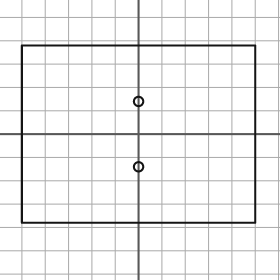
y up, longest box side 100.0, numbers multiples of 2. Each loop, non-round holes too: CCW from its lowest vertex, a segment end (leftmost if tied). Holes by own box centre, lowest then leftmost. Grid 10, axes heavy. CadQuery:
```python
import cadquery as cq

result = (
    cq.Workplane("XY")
    .moveTo(-50.0, -38.0)
    .lineTo(50.0, -38.0)
    .lineTo(50.0, 38.0)
    .lineTo(-50.0, 38.0)
    .close()
    .moveTo(0.0, -14.0)
    .circle(2.0)
    .moveTo(0.0, 14.0)
    .circle(2.0)
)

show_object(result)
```